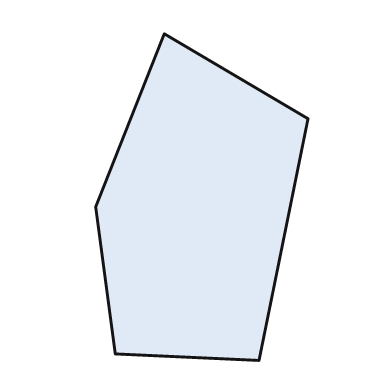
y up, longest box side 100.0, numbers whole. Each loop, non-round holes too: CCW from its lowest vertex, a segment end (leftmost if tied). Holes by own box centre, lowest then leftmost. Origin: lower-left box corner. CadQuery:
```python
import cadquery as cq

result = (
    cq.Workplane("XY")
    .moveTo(50.0, 0.0)
    .lineTo(65.0, 74.0)
    .lineTo(21.0, 100.0)
    .lineTo(0.0, 47.0)
    .lineTo(6.0, 2.0)
    .close()
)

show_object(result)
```